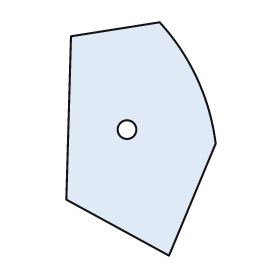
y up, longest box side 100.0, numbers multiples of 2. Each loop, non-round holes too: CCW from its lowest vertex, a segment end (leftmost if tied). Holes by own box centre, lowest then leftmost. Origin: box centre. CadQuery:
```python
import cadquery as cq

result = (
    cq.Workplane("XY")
    .moveTo(12.0, -50.0)
    .lineTo(32.0, -2.0)
    .threePointArc((24.0, 26.0), (8.0, 50.0))
    .lineTo(-30.0, 44.0)
    .lineTo(-32.0, -26.0)
    .close()
    .moveTo(-6.0, 4.0)
    .circle(4.0)
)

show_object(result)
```